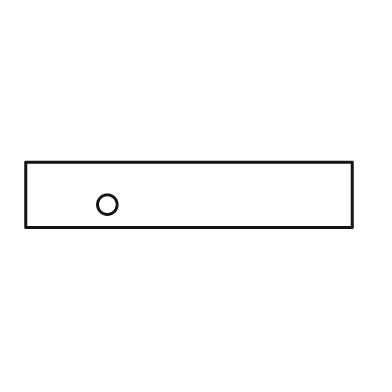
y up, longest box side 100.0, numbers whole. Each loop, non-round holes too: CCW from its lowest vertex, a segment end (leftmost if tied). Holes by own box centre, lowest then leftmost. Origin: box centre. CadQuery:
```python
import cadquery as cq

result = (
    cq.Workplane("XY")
    .moveTo(-50.0, -10.0)
    .lineTo(50.0, -10.0)
    .lineTo(50.0, 10.0)
    .lineTo(-50.0, 10.0)
    .close()
    .moveTo(-25.0, -3.0)
    .circle(3.0)
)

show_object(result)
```